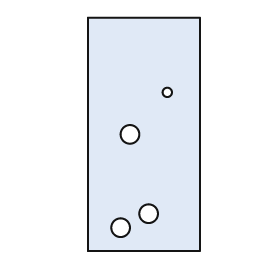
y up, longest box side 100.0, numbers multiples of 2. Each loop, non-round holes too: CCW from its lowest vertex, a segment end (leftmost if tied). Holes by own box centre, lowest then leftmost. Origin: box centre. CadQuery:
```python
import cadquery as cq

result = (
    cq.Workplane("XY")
    .moveTo(-24.0, -50.0)
    .lineTo(24.0, -50.0)
    .lineTo(24.0, 50.0)
    .lineTo(-24.0, 50.0)
    .close()
    .moveTo(-10.0, -40.0)
    .circle(4.0)
    .moveTo(2.0, -34.0)
    .circle(4.0)
    .moveTo(-6.0, 0.0)
    .circle(4.0)
    .moveTo(10.0, 18.0)
    .circle(2.0)
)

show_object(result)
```